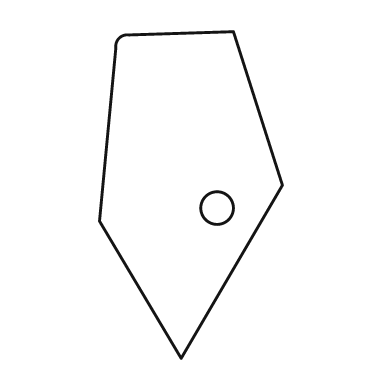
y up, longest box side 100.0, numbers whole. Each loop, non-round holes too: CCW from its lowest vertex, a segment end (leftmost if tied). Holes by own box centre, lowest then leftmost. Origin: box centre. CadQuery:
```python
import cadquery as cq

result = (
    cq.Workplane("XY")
    .moveTo(-3.0, -50.0)
    .lineTo(28.0, 3.0)
    .lineTo(13.0, 50.0)
    .lineTo(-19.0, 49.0)
    .threePointArc((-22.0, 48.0), (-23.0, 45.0))
    .lineTo(-28.0, -8.0)
    .close()
    .moveTo(8.0, -4.0)
    .circle(5.0)
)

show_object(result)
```